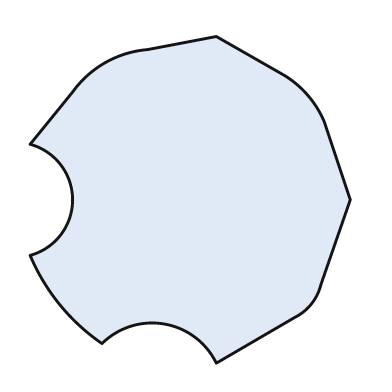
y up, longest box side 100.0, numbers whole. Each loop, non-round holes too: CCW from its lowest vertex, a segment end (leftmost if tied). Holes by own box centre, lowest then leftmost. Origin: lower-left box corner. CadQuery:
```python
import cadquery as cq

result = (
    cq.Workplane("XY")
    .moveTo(57.0, 0.0)
    .lineTo(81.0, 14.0)
    .threePointArc((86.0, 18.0), (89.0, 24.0))
    .lineTo(98.0, 50.0)
    .lineTo(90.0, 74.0)
    .threePointArc((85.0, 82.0), (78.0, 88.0))
    .lineTo(57.0, 100.0)
    .lineTo(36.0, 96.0)
    .threePointArc((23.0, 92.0), (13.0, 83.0))
    .lineTo(0.0, 67.0)
    .threePointArc((13.0, 50.0), (0.0, 33.0))
    .threePointArc((9.0, 18.0), (22.0, 6.0))
    .threePointArc((41.0, 12.0), (57.0, 0.0))
    .close()
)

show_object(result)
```